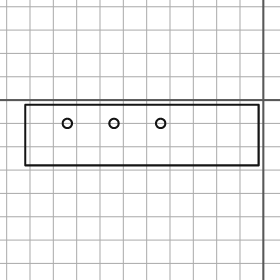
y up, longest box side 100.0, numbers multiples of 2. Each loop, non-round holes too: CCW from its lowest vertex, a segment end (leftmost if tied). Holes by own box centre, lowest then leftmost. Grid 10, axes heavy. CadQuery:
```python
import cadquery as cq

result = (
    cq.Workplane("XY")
    .moveTo(-102.0, -28.0)
    .lineTo(-2.0, -28.0)
    .lineTo(-2.0, -2.0)
    .lineTo(-102.0, -2.0)
    .close()
    .moveTo(-84.0, -10.0)
    .circle(2.0)
    .moveTo(-64.0, -10.0)
    .circle(2.0)
    .moveTo(-44.0, -10.0)
    .circle(2.0)
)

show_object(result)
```